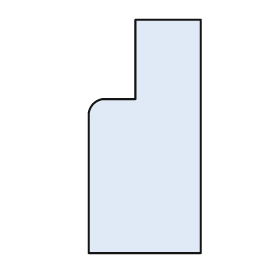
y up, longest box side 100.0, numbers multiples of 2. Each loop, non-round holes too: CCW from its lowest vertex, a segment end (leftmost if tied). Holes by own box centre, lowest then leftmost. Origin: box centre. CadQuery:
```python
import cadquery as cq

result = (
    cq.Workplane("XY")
    .moveTo(-24.0, -50.0)
    .lineTo(24.0, -50.0)
    .lineTo(24.0, 50.0)
    .lineTo(-4.0, 50.0)
    .lineTo(-4.0, 16.0)
    .lineTo(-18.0, 16.0)
    .threePointArc((-22.0, 14.0), (-24.0, 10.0))
    .close()
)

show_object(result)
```